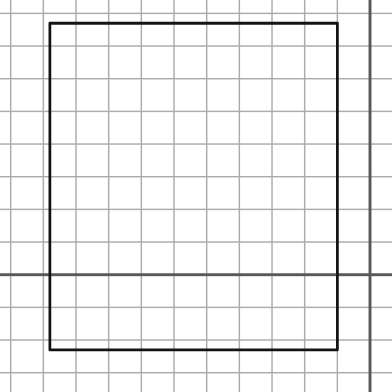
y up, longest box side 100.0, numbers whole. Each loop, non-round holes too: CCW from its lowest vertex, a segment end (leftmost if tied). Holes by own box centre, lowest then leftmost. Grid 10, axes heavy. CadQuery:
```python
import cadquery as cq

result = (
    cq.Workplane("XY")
    .moveTo(-98.0, -23.0)
    .lineTo(-10.0, -23.0)
    .lineTo(-10.0, 77.0)
    .lineTo(-98.0, 77.0)
    .close()
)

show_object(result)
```